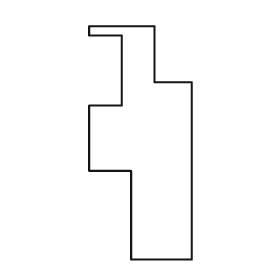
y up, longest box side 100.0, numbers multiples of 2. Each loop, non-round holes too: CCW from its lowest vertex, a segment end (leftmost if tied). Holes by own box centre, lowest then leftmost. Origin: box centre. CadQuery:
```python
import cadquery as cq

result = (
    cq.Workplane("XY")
    .moveTo(-4.0, -50.0)
    .lineTo(22.0, -50.0)
    .lineTo(22.0, 26.0)
    .lineTo(6.0, 26.0)
    .lineTo(6.0, 50.0)
    .lineTo(-22.0, 50.0)
    .lineTo(-22.0, 46.0)
    .lineTo(-8.0, 46.0)
    .lineTo(-8.0, 16.0)
    .lineTo(-22.0, 16.0)
    .lineTo(-22.0, -12.0)
    .lineTo(-4.0, -12.0)
    .close()
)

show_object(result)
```